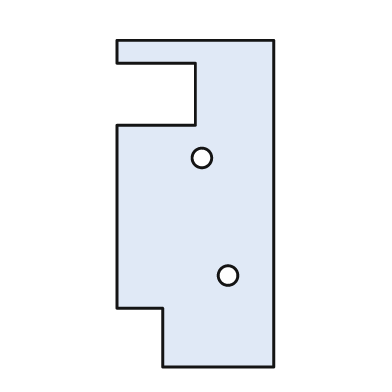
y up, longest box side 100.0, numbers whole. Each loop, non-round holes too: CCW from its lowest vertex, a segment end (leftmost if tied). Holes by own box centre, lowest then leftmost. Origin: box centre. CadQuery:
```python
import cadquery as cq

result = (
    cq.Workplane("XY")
    .moveTo(-10.0, -50.0)
    .lineTo(24.0, -50.0)
    .lineTo(24.0, 50.0)
    .lineTo(-24.0, 50.0)
    .lineTo(-24.0, 43.0)
    .lineTo(0.0, 43.0)
    .lineTo(0.0, 24.0)
    .lineTo(-24.0, 24.0)
    .lineTo(-24.0, -32.0)
    .lineTo(-10.0, -32.0)
    .close()
    .moveTo(10.0, -22.0)
    .circle(3.0)
    .moveTo(2.0, 14.0)
    .circle(3.0)
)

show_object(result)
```